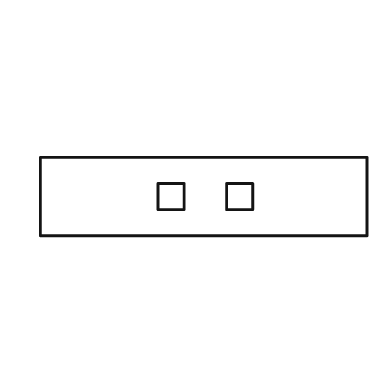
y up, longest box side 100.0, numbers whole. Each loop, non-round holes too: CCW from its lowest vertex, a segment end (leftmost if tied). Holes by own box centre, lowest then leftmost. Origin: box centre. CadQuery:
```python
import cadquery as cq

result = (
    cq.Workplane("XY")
    .moveTo(-50.0, -12.0)
    .lineTo(50.0, -12.0)
    .lineTo(50.0, 12.0)
    .lineTo(-50.0, 12.0)
    .close()
    .moveTo(-14.0, -4.0)
    .lineTo(-6.0, -4.0)
    .lineTo(-6.0, 4.0)
    .lineTo(-14.0, 4.0)
    .close()
    .moveTo(7.0, -4.0)
    .lineTo(15.0, -4.0)
    .lineTo(15.0, 4.0)
    .lineTo(7.0, 4.0)
    .close()
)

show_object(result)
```